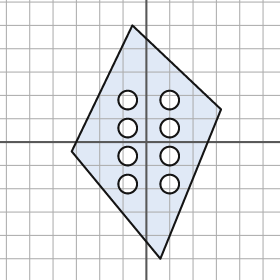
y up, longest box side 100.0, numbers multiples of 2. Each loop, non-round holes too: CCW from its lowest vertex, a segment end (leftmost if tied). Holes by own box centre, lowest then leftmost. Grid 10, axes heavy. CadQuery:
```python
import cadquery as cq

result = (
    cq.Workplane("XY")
    .moveTo(6.0, -50.0)
    .lineTo(32.0, 14.0)
    .lineTo(-6.0, 50.0)
    .lineTo(-32.0, -4.0)
    .close()
    .moveTo(-8.0, -18.0)
    .circle(4.0)
    .moveTo(10.0, -18.0)
    .circle(4.0)
    .moveTo(-8.0, -6.0)
    .circle(4.0)
    .moveTo(10.0, -6.0)
    .circle(4.0)
    .moveTo(-8.0, 6.0)
    .circle(4.0)
    .moveTo(10.0, 6.0)
    .circle(4.0)
    .moveTo(-8.0, 18.0)
    .circle(4.0)
    .moveTo(10.0, 18.0)
    .circle(4.0)
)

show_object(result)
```